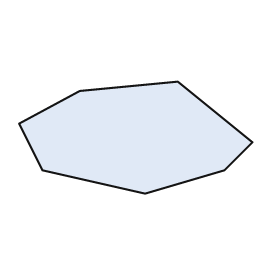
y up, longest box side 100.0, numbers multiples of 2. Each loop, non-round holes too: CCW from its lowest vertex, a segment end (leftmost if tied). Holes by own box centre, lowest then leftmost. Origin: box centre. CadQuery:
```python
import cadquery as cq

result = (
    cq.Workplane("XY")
    .moveTo(4.0, -24.0)
    .lineTo(38.0, -14.0)
    .lineTo(50.0, -2.0)
    .lineTo(18.0, 24.0)
    .lineTo(-24.0, 20.0)
    .lineTo(-50.0, 6.0)
    .lineTo(-40.0, -14.0)
    .close()
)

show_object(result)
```